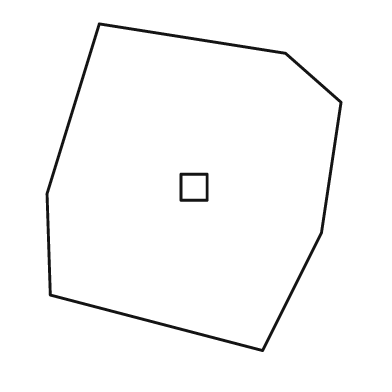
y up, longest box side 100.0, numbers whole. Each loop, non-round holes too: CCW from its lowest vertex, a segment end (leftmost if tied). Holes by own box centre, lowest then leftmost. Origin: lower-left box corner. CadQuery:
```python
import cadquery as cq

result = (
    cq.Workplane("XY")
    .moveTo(66.0, 0.0)
    .lineTo(84.0, 36.0)
    .lineTo(90.0, 76.0)
    .lineTo(73.0, 91.0)
    .lineTo(16.0, 100.0)
    .lineTo(0.0, 48.0)
    .lineTo(1.0, 17.0)
    .close()
    .moveTo(41.0, 46.0)
    .lineTo(49.0, 46.0)
    .lineTo(49.0, 54.0)
    .lineTo(41.0, 54.0)
    .close()
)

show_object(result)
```